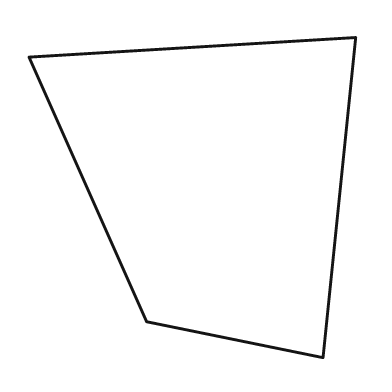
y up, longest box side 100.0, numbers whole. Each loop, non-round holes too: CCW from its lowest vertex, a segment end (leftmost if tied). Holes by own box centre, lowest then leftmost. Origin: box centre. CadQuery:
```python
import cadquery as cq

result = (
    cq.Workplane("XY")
    .moveTo(40.0, -49.0)
    .lineTo(50.0, 49.0)
    .lineTo(-50.0, 43.0)
    .lineTo(-14.0, -38.0)
    .close()
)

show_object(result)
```